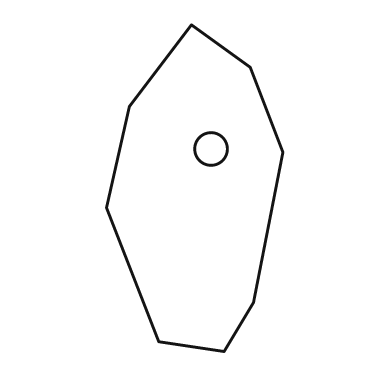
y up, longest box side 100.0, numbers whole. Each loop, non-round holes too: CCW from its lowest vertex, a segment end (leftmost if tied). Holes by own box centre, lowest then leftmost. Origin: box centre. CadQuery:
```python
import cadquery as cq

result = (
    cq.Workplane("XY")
    .moveTo(9.0, -50.0)
    .lineTo(18.0, -35.0)
    .lineTo(27.0, 11.0)
    .lineTo(17.0, 37.0)
    .lineTo(-1.0, 50.0)
    .lineTo(-20.0, 25.0)
    .lineTo(-27.0, -6.0)
    .lineTo(-11.0, -47.0)
    .close()
    .moveTo(5.0, 12.0)
    .circle(5.0)
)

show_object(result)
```